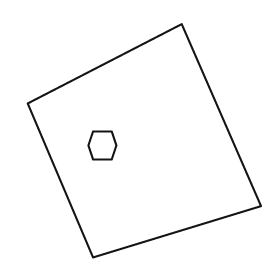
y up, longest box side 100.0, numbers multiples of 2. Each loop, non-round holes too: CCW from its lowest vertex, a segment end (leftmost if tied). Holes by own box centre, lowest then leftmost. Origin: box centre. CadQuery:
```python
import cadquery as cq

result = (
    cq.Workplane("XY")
    .moveTo(-22.0, -50.0)
    .lineTo(50.0, -28.0)
    .lineTo(16.0, 50.0)
    .lineTo(-50.0, 16.0)
    .close()
    .moveTo(-22.0, -8.0)
    .lineTo(-14.0, -8.0)
    .lineTo(-12.0, -2.0)
    .lineTo(-14.0, 4.0)
    .lineTo(-22.0, 4.0)
    .lineTo(-24.0, -2.0)
    .close()
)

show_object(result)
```